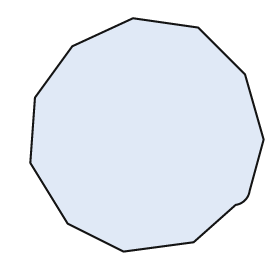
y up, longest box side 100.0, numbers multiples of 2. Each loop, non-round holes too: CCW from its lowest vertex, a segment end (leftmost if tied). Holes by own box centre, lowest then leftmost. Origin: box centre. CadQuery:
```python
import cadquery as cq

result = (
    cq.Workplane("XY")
    .moveTo(-10.0, -50.0)
    .lineTo(20.0, -46.0)
    .lineTo(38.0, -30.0)
    .threePointArc((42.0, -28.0), (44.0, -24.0))
    .lineTo(50.0, -2.0)
    .lineTo(42.0, 26.0)
    .lineTo(22.0, 46.0)
    .lineTo(-6.0, 50.0)
    .lineTo(-32.0, 38.0)
    .lineTo(-48.0, 16.0)
    .lineTo(-50.0, -12.0)
    .lineTo(-34.0, -38.0)
    .close()
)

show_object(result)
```